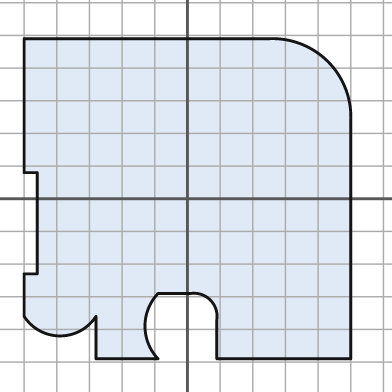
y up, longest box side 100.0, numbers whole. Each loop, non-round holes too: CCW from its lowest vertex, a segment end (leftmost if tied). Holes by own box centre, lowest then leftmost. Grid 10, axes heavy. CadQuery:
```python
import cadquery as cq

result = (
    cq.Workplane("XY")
    .moveTo(-28.0, -49.0)
    .lineTo(-9.0, -49.0)
    .threePointArc((-13.0, -39.0), (-9.0, -29.0))
    .lineTo(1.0, -29.0)
    .threePointArc((7.0, -31.0), (9.0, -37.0))
    .lineTo(9.0, -49.0)
    .lineTo(50.0, -49.0)
    .lineTo(50.0, 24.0)
    .threePointArc((43.0, 42.0), (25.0, 49.0))
    .lineTo(-50.0, 49.0)
    .lineTo(-50.0, 8.0)
    .lineTo(-46.0, 8.0)
    .lineTo(-46.0, -23.0)
    .lineTo(-50.0, -23.0)
    .lineTo(-50.0, -36.0)
    .threePointArc((-39.0, -42.0), (-28.0, -36.0))
    .close()
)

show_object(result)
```